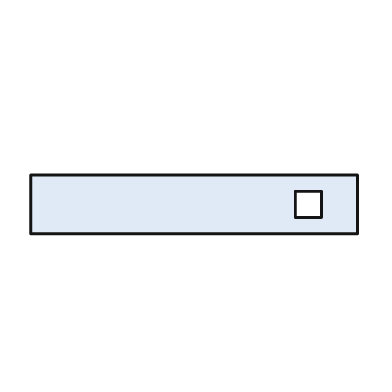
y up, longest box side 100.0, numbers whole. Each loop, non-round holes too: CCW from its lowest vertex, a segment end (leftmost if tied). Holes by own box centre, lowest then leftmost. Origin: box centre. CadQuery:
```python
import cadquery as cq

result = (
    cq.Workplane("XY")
    .moveTo(-50.0, -9.0)
    .lineTo(50.0, -9.0)
    .lineTo(50.0, 9.0)
    .lineTo(-50.0, 9.0)
    .close()
    .moveTo(31.0, -4.0)
    .lineTo(39.0, -4.0)
    .lineTo(39.0, 4.0)
    .lineTo(31.0, 4.0)
    .close()
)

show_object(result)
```